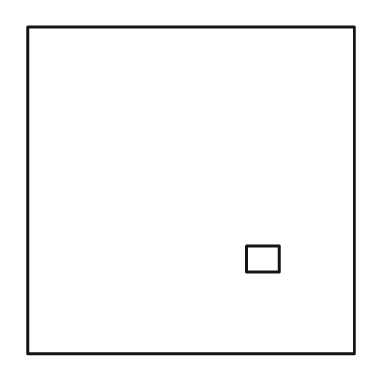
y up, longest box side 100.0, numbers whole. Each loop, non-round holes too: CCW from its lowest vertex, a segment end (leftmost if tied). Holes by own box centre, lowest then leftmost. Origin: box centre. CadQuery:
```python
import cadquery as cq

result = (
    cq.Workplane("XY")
    .moveTo(-50.0, -50.0)
    .lineTo(50.0, -50.0)
    .lineTo(50.0, 50.0)
    .lineTo(-50.0, 50.0)
    .close()
    .moveTo(17.0, -25.0)
    .lineTo(27.0, -25.0)
    .lineTo(27.0, -17.0)
    .lineTo(17.0, -17.0)
    .close()
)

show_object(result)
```